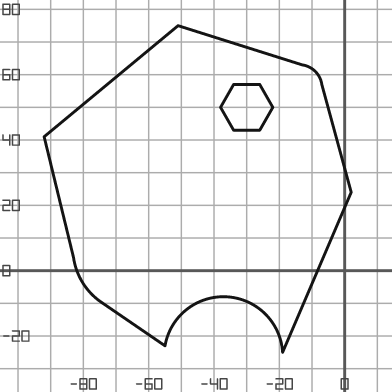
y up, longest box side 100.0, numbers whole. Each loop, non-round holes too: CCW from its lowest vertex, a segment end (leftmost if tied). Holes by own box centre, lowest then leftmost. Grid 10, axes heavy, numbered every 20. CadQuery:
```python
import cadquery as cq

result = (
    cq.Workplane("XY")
    .moveTo(-19.0, -25.0)
    .lineTo(2.0, 24.0)
    .lineTo(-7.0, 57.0)
    .threePointArc((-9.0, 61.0), (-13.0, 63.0))
    .lineTo(-51.0, 75.0)
    .lineTo(-92.0, 41.0)
    .lineTo(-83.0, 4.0)
    .threePointArc((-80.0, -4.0), (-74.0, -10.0))
    .lineTo(-55.0, -23.0)
    .threePointArc((-36.0, -8.0), (-19.0, -25.0))
    .close()
    .moveTo(-34.0, 43.0)
    .lineTo(-26.0, 43.0)
    .lineTo(-22.0, 50.0)
    .lineTo(-26.0, 57.0)
    .lineTo(-34.0, 57.0)
    .lineTo(-38.0, 50.0)
    .close()
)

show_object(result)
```